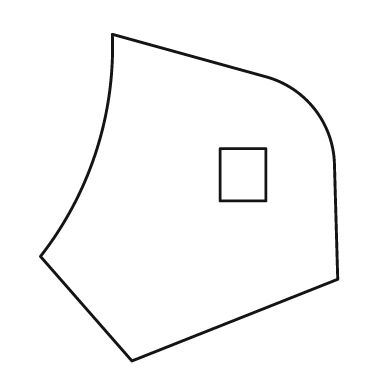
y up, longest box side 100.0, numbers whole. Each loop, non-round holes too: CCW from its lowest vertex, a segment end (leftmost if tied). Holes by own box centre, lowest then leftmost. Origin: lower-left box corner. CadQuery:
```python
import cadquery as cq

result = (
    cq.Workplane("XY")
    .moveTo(28.0, 0.0)
    .lineTo(91.0, 25.0)
    .lineTo(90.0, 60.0)
    .threePointArc((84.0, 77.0), (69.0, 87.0))
    .lineTo(22.0, 100.0)
    .threePointArc((17.0, 64.0), (0.0, 32.0))
    .close()
    .moveTo(55.0, 49.0)
    .lineTo(69.0, 49.0)
    .lineTo(69.0, 65.0)
    .lineTo(55.0, 65.0)
    .close()
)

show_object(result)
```